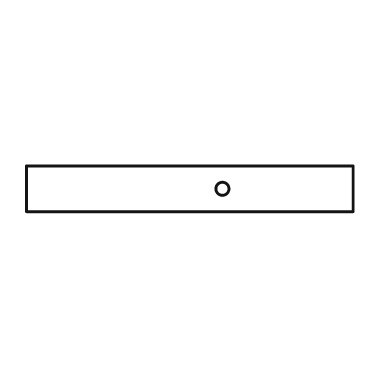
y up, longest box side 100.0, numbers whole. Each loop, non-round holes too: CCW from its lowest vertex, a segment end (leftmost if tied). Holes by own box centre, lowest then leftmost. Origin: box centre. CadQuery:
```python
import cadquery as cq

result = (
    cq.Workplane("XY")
    .moveTo(-50.0, -7.0)
    .lineTo(50.0, -7.0)
    .lineTo(50.0, 7.0)
    .lineTo(-50.0, 7.0)
    .close()
    .moveTo(10.0, 0.0)
    .circle(2.0)
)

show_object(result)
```